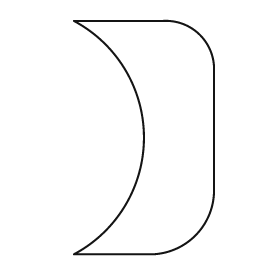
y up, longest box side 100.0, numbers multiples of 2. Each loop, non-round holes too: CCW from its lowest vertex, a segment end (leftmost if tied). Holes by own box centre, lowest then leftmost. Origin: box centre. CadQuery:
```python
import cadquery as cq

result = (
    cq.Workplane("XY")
    .moveTo(-30.0, -50.0)
    .lineTo(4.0, -50.0)
    .threePointArc((22.0, -42.0), (30.0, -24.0))
    .lineTo(30.0, 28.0)
    .threePointArc((24.0, 44.0), (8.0, 50.0))
    .lineTo(-30.0, 50.0)
    .threePointArc((0.0, 0.0), (-30.0, -50.0))
    .close()
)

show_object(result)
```